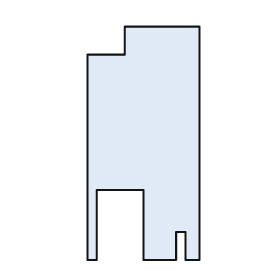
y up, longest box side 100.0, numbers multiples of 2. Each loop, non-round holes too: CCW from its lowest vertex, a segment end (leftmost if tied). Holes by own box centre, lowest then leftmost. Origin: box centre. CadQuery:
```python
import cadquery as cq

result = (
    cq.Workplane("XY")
    .moveTo(-24.0, -50.0)
    .lineTo(-20.0, -50.0)
    .lineTo(-20.0, -20.0)
    .lineTo(0.0, -20.0)
    .lineTo(0.0, -50.0)
    .lineTo(14.0, -50.0)
    .lineTo(14.0, -38.0)
    .lineTo(18.0, -38.0)
    .lineTo(18.0, -50.0)
    .lineTo(24.0, -50.0)
    .lineTo(24.0, 50.0)
    .lineTo(-8.0, 50.0)
    .lineTo(-8.0, 38.0)
    .lineTo(-24.0, 38.0)
    .close()
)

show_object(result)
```